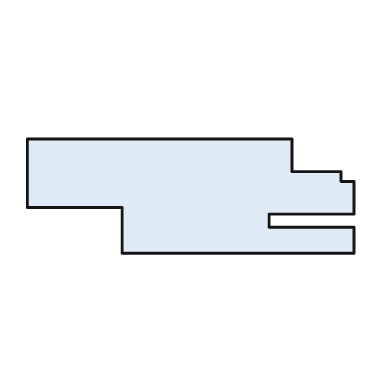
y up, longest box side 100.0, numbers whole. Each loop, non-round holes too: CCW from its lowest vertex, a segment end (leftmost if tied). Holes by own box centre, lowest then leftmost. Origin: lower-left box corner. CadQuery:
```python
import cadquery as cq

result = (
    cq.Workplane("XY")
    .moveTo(29.0, 0.0)
    .lineTo(100.0, 0.0)
    .lineTo(100.0, 8.0)
    .lineTo(74.0, 8.0)
    .lineTo(74.0, 12.0)
    .lineTo(100.0, 12.0)
    .lineTo(100.0, 22.0)
    .lineTo(96.0, 22.0)
    .lineTo(96.0, 25.0)
    .lineTo(81.0, 25.0)
    .lineTo(81.0, 35.0)
    .lineTo(0.0, 35.0)
    .lineTo(0.0, 14.0)
    .lineTo(29.0, 14.0)
    .close()
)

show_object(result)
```